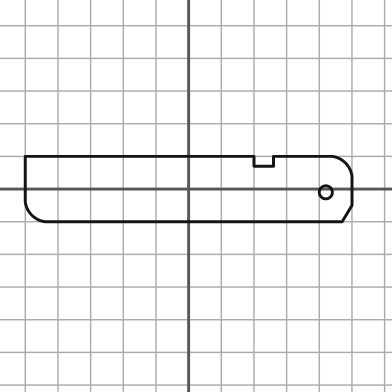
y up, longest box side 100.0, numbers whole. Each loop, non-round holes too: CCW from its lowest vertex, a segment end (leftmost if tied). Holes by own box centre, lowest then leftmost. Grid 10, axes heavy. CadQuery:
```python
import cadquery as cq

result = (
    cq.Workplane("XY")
    .moveTo(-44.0, -10.0)
    .lineTo(47.0, -10.0)
    .lineTo(50.0, -5.0)
    .lineTo(50.0, 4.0)
    .threePointArc((48.0, 8.0), (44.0, 10.0))
    .lineTo(26.0, 10.0)
    .lineTo(26.0, 7.0)
    .lineTo(20.0, 7.0)
    .lineTo(20.0, 10.0)
    .lineTo(-50.0, 10.0)
    .lineTo(-50.0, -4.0)
    .threePointArc((-48.0, -8.0), (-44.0, -10.0))
    .close()
    .moveTo(42.0, -1.0)
    .circle(2.0)
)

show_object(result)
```